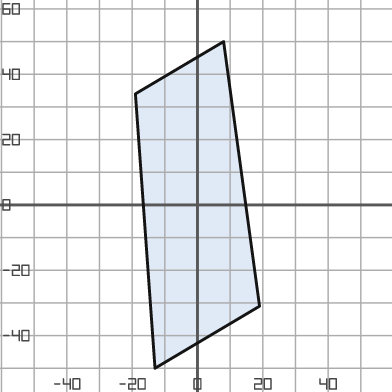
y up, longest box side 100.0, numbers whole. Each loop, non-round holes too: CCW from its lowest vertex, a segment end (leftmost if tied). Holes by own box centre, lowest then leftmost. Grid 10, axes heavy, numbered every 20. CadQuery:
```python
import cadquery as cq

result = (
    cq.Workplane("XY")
    .moveTo(-13.0, -50.0)
    .lineTo(19.0, -31.0)
    .lineTo(8.0, 50.0)
    .lineTo(-19.0, 34.0)
    .close()
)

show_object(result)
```